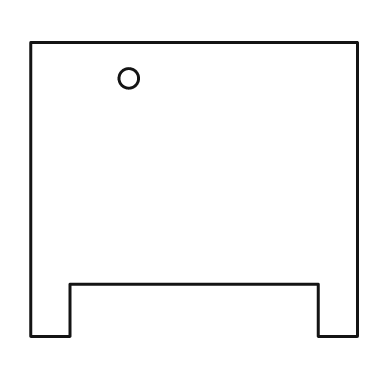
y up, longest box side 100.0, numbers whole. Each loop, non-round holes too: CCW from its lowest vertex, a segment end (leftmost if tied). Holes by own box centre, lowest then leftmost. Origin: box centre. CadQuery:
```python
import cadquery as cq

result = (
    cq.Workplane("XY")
    .moveTo(-50.0, -45.0)
    .lineTo(-38.0, -45.0)
    .lineTo(-38.0, -29.0)
    .lineTo(38.0, -29.0)
    .lineTo(38.0, -45.0)
    .lineTo(50.0, -45.0)
    .lineTo(50.0, 45.0)
    .lineTo(-50.0, 45.0)
    .close()
    .moveTo(-20.0, 34.0)
    .circle(3.0)
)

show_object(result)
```